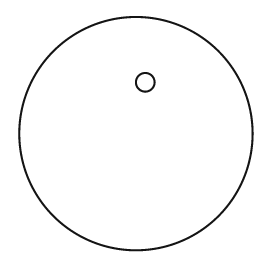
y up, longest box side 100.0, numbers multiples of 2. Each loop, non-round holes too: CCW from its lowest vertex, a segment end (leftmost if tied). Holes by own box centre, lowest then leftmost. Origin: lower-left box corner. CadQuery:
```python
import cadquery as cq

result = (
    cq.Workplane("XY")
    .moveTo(50.0, 50.0)
    .circle(50.0)
    .moveTo(54.0, 72.0)
    .circle(4.0)
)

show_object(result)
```